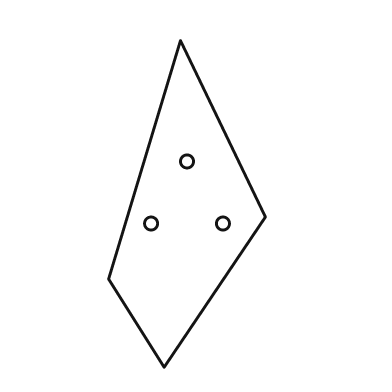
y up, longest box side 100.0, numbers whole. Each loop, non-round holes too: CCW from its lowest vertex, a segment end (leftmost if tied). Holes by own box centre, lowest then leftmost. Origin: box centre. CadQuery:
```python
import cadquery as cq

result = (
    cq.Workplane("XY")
    .moveTo(-7.0, -50.0)
    .lineTo(24.0, -4.0)
    .lineTo(-2.0, 50.0)
    .lineTo(-24.0, -23.0)
    .close()
    .moveTo(-11.0, -6.0)
    .circle(2.0)
    .moveTo(11.0, -6.0)
    .circle(2.0)
    .moveTo(0.0, 13.0)
    .circle(2.0)
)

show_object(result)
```